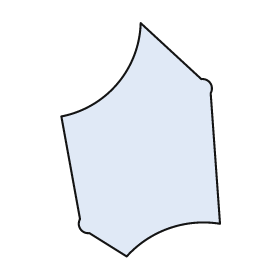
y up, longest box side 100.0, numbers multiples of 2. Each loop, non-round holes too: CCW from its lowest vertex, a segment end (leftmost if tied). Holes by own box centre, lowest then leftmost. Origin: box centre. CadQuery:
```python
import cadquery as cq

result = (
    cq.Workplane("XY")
    .moveTo(-6.0, -50.0)
    .threePointArc((12.0, -38.0), (34.0, -36.0))
    .lineTo(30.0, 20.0)
    .threePointArc((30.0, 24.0), (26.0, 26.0))
    .lineTo(0.0, 50.0)
    .threePointArc((-10.0, 24.0), (-34.0, 10.0))
    .lineTo(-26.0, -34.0)
    .threePointArc((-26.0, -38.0), (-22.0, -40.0))
    .close()
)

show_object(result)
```